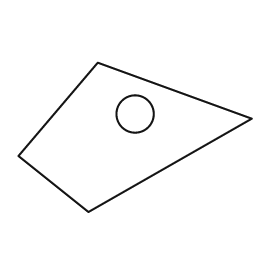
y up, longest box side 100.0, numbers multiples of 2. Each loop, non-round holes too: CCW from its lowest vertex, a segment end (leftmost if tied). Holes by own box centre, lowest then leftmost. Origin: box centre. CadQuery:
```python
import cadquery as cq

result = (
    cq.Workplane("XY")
    .moveTo(-20.0, -32.0)
    .lineTo(50.0, 8.0)
    .lineTo(-16.0, 32.0)
    .lineTo(-50.0, -8.0)
    .close()
    .moveTo(0.0, 10.0)
    .circle(8.0)
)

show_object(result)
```